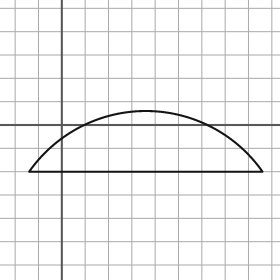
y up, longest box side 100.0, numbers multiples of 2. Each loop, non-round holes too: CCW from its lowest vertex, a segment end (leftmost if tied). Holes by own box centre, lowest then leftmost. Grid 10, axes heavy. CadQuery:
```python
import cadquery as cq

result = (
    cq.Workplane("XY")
    .moveTo(-14.0, -20.0)
    .lineTo(86.0, -20.0)
    .threePointArc((36.0, 6.0), (-14.0, -20.0))
    .close()
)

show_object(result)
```